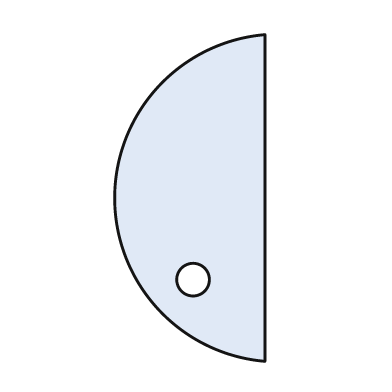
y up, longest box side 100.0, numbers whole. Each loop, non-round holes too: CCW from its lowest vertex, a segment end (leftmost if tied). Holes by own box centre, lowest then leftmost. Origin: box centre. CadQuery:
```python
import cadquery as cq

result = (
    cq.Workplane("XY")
    .moveTo(23.0, -50.0)
    .lineTo(23.0, 50.0)
    .threePointArc((-23.0, 0.0), (23.0, -50.0))
    .close()
    .moveTo(1.0, -25.0)
    .circle(5.0)
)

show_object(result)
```